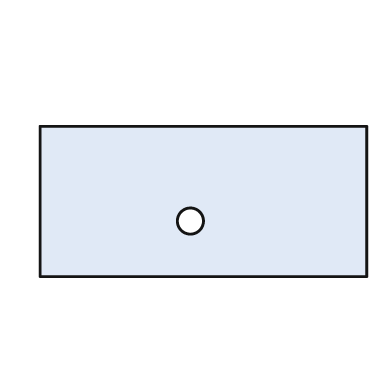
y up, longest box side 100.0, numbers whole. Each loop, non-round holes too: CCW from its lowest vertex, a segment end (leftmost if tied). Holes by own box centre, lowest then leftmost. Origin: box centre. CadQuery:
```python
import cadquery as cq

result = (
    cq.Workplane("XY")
    .moveTo(-50.0, -23.0)
    .lineTo(50.0, -23.0)
    .lineTo(50.0, 23.0)
    .lineTo(-50.0, 23.0)
    .close()
    .moveTo(-4.0, -6.0)
    .circle(4.0)
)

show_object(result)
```